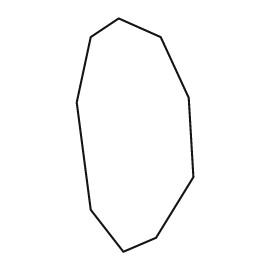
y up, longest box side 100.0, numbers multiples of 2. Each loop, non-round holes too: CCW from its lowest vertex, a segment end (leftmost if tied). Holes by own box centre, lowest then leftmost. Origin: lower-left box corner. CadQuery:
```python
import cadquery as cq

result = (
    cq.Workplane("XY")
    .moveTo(20.0, 0.0)
    .lineTo(34.0, 6.0)
    .lineTo(50.0, 32.0)
    .lineTo(48.0, 66.0)
    .lineTo(36.0, 92.0)
    .lineTo(18.0, 100.0)
    .lineTo(6.0, 92.0)
    .lineTo(0.0, 64.0)
    .lineTo(6.0, 18.0)
    .close()
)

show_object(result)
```